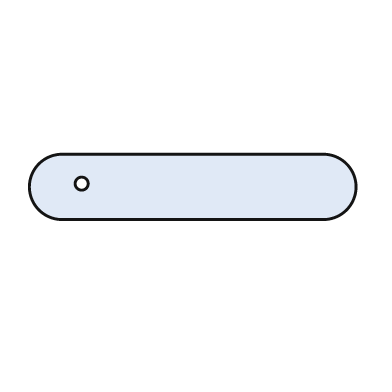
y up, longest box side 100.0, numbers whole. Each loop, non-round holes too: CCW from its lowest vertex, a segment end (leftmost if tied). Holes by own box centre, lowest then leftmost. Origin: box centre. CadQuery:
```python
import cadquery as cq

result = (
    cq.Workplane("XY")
    .moveTo(-40.0, -10.0)
    .lineTo(40.0, -10.0)
    .threePointArc((50.0, 0.0), (40.0, 10.0))
    .lineTo(-40.0, 10.0)
    .threePointArc((-50.0, 0.0), (-40.0, -10.0))
    .close()
    .moveTo(-34.0, 1.0)
    .circle(2.0)
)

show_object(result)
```